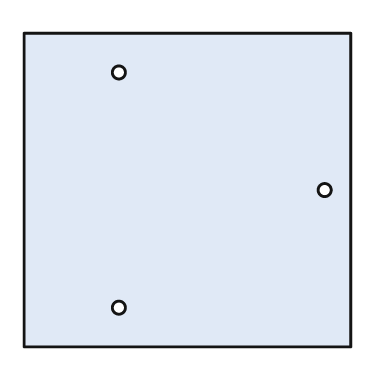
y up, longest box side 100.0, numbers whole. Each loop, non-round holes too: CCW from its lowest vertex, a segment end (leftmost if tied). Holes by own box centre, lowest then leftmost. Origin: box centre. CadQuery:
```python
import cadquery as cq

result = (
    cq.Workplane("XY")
    .moveTo(-50.0, -48.0)
    .lineTo(50.0, -48.0)
    .lineTo(50.0, 48.0)
    .lineTo(-50.0, 48.0)
    .close()
    .moveTo(-21.0, -36.0)
    .circle(2.0)
    .moveTo(42.0, 0.0)
    .circle(2.0)
    .moveTo(-21.0, 36.0)
    .circle(2.0)
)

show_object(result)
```